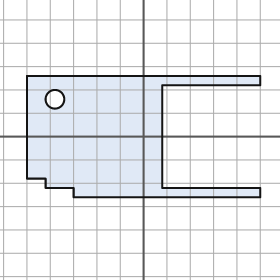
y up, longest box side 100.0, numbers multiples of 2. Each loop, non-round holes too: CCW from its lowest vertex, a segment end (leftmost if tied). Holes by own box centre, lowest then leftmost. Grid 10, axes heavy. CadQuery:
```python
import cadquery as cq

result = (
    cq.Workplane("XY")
    .moveTo(-30.0, -26.0)
    .lineTo(50.0, -26.0)
    .lineTo(50.0, -22.0)
    .lineTo(8.0, -22.0)
    .lineTo(8.0, 22.0)
    .lineTo(50.0, 22.0)
    .lineTo(50.0, 26.0)
    .lineTo(-50.0, 26.0)
    .lineTo(-50.0, -18.0)
    .lineTo(-42.0, -18.0)
    .lineTo(-42.0, -22.0)
    .lineTo(-30.0, -22.0)
    .close()
    .moveTo(-38.0, 16.0)
    .circle(4.0)
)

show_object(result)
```